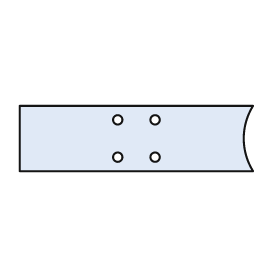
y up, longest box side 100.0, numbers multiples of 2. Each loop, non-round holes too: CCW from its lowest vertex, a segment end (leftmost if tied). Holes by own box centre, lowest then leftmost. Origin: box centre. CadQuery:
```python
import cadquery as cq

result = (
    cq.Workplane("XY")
    .moveTo(-50.0, -14.0)
    .lineTo(50.0, -14.0)
    .threePointArc((46.0, 0.0), (50.0, 14.0))
    .lineTo(-50.0, 14.0)
    .close()
    .moveTo(-8.0, -8.0)
    .circle(2.0)
    .moveTo(8.0, -8.0)
    .circle(2.0)
    .moveTo(-8.0, 8.0)
    .circle(2.0)
    .moveTo(8.0, 8.0)
    .circle(2.0)
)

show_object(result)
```